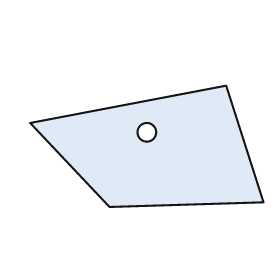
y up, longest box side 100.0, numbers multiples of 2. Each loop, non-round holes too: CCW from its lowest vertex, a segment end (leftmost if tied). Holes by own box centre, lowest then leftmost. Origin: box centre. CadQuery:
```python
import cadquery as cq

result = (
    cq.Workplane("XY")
    .moveTo(-16.0, -26.0)
    .lineTo(50.0, -24.0)
    .lineTo(34.0, 26.0)
    .lineTo(-50.0, 10.0)
    .close()
    .moveTo(0.0, 6.0)
    .circle(4.0)
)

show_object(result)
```